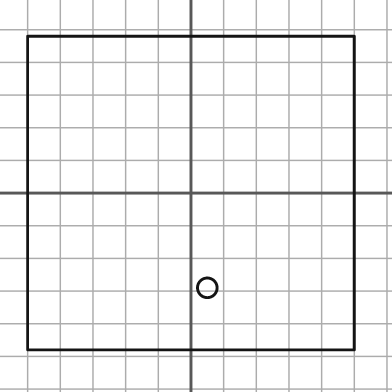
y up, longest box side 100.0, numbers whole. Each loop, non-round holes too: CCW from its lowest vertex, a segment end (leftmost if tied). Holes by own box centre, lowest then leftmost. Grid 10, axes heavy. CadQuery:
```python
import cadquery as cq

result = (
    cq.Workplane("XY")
    .moveTo(-50.0, -48.0)
    .lineTo(50.0, -48.0)
    .lineTo(50.0, 48.0)
    .lineTo(-50.0, 48.0)
    .close()
    .moveTo(5.0, -29.0)
    .circle(3.0)
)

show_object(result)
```